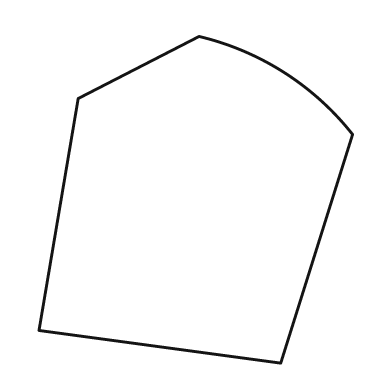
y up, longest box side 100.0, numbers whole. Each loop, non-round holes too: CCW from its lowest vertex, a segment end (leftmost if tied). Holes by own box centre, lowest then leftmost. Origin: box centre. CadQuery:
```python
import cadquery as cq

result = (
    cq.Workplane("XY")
    .moveTo(26.0, -50.0)
    .lineTo(48.0, 20.0)
    .threePointArc((27.0, 39.0), (1.0, 50.0))
    .lineTo(-36.0, 31.0)
    .lineTo(-48.0, -40.0)
    .close()
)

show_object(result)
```